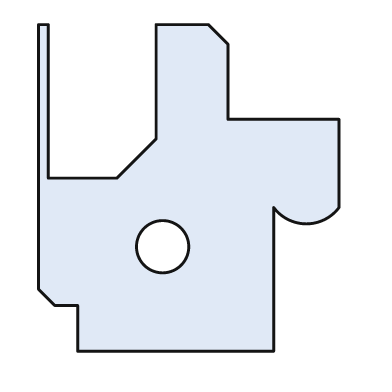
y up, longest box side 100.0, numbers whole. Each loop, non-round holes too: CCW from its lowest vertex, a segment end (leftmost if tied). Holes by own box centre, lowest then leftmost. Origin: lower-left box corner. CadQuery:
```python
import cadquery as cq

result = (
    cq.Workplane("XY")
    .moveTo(12.0, 0.0)
    .lineTo(72.0, 0.0)
    .lineTo(72.0, 44.0)
    .threePointArc((82.0, 39.0), (92.0, 44.0))
    .lineTo(92.0, 71.0)
    .lineTo(58.0, 71.0)
    .lineTo(58.0, 94.0)
    .lineTo(52.0, 100.0)
    .lineTo(36.0, 100.0)
    .lineTo(36.0, 65.0)
    .lineTo(24.0, 53.0)
    .lineTo(3.0, 53.0)
    .lineTo(3.0, 100.0)
    .lineTo(0.0, 100.0)
    .lineTo(0.0, 19.0)
    .lineTo(5.0, 14.0)
    .lineTo(12.0, 14.0)
    .close()
    .moveTo(38.0, 32.0)
    .circle(8.0)
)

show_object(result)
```